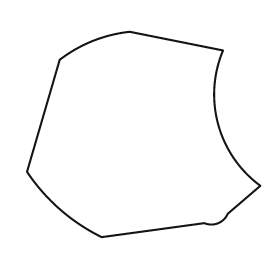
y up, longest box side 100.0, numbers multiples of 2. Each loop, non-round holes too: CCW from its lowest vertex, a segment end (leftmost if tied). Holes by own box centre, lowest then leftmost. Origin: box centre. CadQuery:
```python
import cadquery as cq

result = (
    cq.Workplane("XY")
    .moveTo(-18.0, -44.0)
    .lineTo(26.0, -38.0)
    .threePointArc((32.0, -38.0), (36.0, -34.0))
    .lineTo(50.0, -22.0)
    .threePointArc((32.0, 4.0), (34.0, 36.0))
    .lineTo(-6.0, 44.0)
    .threePointArc((-22.0, 40.0), (-36.0, 32.0))
    .lineTo(-50.0, -16.0)
    .threePointArc((-36.0, -32.0), (-18.0, -44.0))
    .close()
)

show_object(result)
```